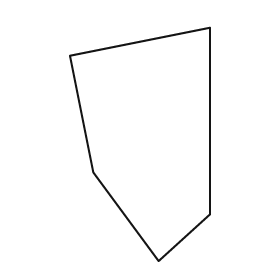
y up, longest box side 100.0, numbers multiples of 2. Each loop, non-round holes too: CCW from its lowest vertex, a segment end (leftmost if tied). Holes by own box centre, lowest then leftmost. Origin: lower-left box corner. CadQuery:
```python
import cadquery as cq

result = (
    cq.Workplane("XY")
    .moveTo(38.0, 0.0)
    .lineTo(60.0, 20.0)
    .lineTo(60.0, 100.0)
    .lineTo(0.0, 88.0)
    .lineTo(10.0, 38.0)
    .close()
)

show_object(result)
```